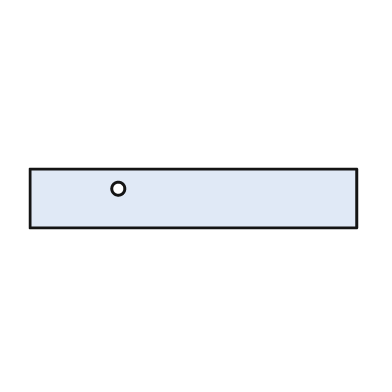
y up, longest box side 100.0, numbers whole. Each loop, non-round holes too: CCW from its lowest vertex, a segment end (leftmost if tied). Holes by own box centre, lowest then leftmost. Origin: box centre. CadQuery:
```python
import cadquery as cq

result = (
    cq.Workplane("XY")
    .moveTo(-50.0, -9.0)
    .lineTo(50.0, -9.0)
    .lineTo(50.0, 9.0)
    .lineTo(-50.0, 9.0)
    .close()
    .moveTo(-23.0, 3.0)
    .circle(2.0)
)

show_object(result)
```